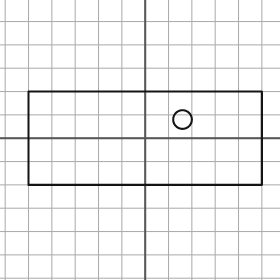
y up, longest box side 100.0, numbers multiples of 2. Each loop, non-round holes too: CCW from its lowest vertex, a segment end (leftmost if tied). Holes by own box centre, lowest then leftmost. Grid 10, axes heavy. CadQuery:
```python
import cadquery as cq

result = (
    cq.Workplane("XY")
    .moveTo(-50.0, -20.0)
    .lineTo(50.0, -20.0)
    .lineTo(50.0, 20.0)
    .lineTo(-50.0, 20.0)
    .close()
    .moveTo(16.0, 8.0)
    .circle(4.0)
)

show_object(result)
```